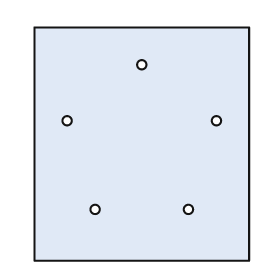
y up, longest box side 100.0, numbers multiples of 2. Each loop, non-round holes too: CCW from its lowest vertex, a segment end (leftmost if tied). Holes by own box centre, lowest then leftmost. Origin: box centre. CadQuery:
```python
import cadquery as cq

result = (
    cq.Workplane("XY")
    .moveTo(-46.0, -50.0)
    .lineTo(46.0, -50.0)
    .lineTo(46.0, 50.0)
    .lineTo(-46.0, 50.0)
    .close()
    .moveTo(-20.0, -28.0)
    .circle(2.0)
    .moveTo(20.0, -28.0)
    .circle(2.0)
    .moveTo(-32.0, 10.0)
    .circle(2.0)
    .moveTo(32.0, 10.0)
    .circle(2.0)
    .moveTo(0.0, 34.0)
    .circle(2.0)
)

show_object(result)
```